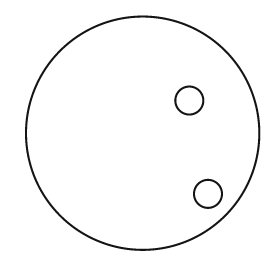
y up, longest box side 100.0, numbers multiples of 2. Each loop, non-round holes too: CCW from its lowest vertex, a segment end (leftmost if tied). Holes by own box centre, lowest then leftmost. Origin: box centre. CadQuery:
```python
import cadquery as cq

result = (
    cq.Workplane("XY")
    .moveTo(0.0, 0.0)
    .circle(50.0)
    .moveTo(28.0, -26.0)
    .circle(6.0)
    .moveTo(20.0, 14.0)
    .circle(6.0)
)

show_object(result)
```